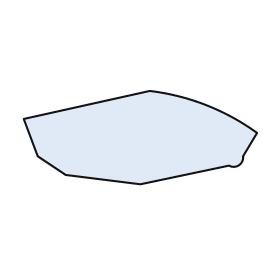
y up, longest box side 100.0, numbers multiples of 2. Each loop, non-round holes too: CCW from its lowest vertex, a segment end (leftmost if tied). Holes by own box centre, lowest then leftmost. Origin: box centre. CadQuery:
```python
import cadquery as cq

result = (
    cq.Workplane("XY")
    .moveTo(0.0, -20.0)
    .lineTo(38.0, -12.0)
    .threePointArc((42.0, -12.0), (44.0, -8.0))
    .lineTo(50.0, 2.0)
    .threePointArc((28.0, 14.0), (4.0, 20.0))
    .lineTo(-50.0, 8.0)
    .lineTo(-44.0, -8.0)
    .lineTo(-32.0, -16.0)
    .close()
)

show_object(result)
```